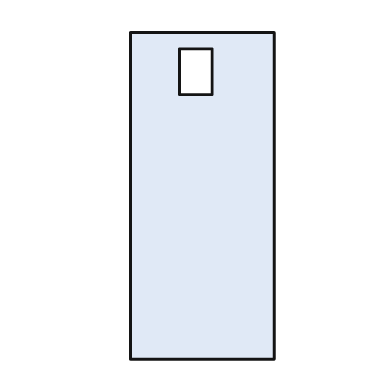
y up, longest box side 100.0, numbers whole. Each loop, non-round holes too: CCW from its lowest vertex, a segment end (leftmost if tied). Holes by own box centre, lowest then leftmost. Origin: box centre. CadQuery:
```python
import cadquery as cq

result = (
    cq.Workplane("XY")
    .moveTo(-22.0, -50.0)
    .lineTo(22.0, -50.0)
    .lineTo(22.0, 50.0)
    .lineTo(-22.0, 50.0)
    .close()
    .moveTo(-7.0, 31.0)
    .lineTo(3.0, 31.0)
    .lineTo(3.0, 45.0)
    .lineTo(-7.0, 45.0)
    .close()
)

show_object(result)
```